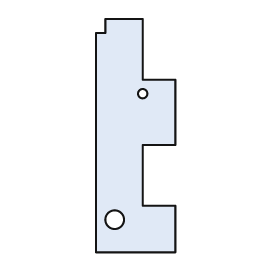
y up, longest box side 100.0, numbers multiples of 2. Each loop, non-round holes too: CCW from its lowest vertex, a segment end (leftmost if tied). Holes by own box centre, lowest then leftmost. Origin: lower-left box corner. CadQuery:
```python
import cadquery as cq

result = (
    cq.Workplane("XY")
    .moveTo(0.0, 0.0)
    .lineTo(34.0, 0.0)
    .lineTo(34.0, 20.0)
    .lineTo(20.0, 20.0)
    .lineTo(20.0, 46.0)
    .lineTo(34.0, 46.0)
    .lineTo(34.0, 74.0)
    .lineTo(20.0, 74.0)
    .lineTo(20.0, 100.0)
    .lineTo(4.0, 100.0)
    .lineTo(4.0, 94.0)
    .lineTo(0.0, 94.0)
    .close()
    .moveTo(8.0, 14.0)
    .circle(4.0)
    .moveTo(20.0, 68.0)
    .circle(2.0)
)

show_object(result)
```